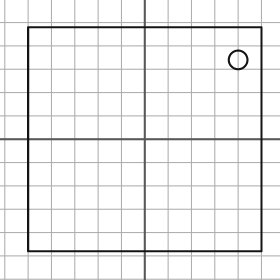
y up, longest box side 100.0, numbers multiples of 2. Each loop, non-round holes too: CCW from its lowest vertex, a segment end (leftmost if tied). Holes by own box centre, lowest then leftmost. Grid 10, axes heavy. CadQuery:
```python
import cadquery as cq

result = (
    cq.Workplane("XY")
    .moveTo(-50.0, -48.0)
    .lineTo(50.0, -48.0)
    .lineTo(50.0, 48.0)
    .lineTo(-50.0, 48.0)
    .close()
    .moveTo(40.0, 34.0)
    .circle(4.0)
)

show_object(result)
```